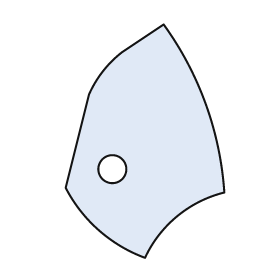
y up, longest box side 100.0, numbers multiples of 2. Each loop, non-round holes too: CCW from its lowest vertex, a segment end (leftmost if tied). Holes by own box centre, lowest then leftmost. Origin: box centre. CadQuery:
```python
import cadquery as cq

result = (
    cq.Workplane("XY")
    .moveTo(0.0, -50.0)
    .threePointArc((14.0, -32.0), (34.0, -22.0))
    .threePointArc((26.0, 16.0), (8.0, 50.0))
    .lineTo(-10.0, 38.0)
    .threePointArc((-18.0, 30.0), (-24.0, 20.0))
    .lineTo(-34.0, -20.0)
    .threePointArc((-20.0, -38.0), (0.0, -50.0))
    .close()
    .moveTo(-14.0, -12.0)
    .circle(6.0)
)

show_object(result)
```